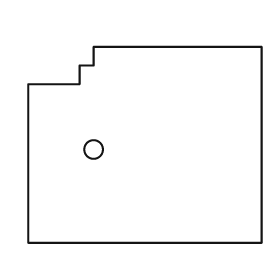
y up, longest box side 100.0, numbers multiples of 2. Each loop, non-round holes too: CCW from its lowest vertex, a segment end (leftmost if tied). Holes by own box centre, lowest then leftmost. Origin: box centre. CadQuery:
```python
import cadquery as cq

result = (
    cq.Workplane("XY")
    .moveTo(-50.0, -42.0)
    .lineTo(50.0, -42.0)
    .lineTo(50.0, 42.0)
    .lineTo(-22.0, 42.0)
    .lineTo(-22.0, 34.0)
    .lineTo(-28.0, 34.0)
    .lineTo(-28.0, 26.0)
    .lineTo(-50.0, 26.0)
    .close()
    .moveTo(-22.0, -2.0)
    .circle(4.0)
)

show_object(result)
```